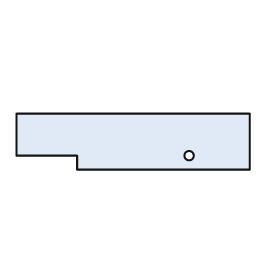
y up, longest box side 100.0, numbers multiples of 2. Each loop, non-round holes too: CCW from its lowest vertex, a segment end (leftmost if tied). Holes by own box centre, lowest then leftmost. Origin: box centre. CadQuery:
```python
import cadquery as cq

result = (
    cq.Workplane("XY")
    .moveTo(-24.0, -12.0)
    .lineTo(50.0, -12.0)
    .lineTo(50.0, 12.0)
    .lineTo(-50.0, 12.0)
    .lineTo(-50.0, -6.0)
    .lineTo(-24.0, -6.0)
    .close()
    .moveTo(24.0, -6.0)
    .circle(2.0)
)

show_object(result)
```